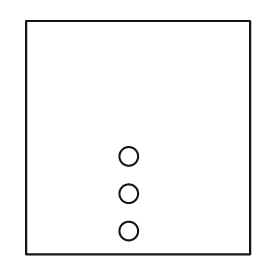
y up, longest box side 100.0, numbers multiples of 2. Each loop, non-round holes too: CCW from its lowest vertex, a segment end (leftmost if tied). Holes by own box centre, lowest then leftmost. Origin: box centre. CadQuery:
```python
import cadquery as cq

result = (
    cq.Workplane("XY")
    .moveTo(-48.0, -50.0)
    .lineTo(48.0, -50.0)
    .lineTo(48.0, 50.0)
    .lineTo(-48.0, 50.0)
    .close()
    .moveTo(-4.0, -40.0)
    .circle(4.0)
    .moveTo(-4.0, -24.0)
    .circle(4.0)
    .moveTo(-4.0, -8.0)
    .circle(4.0)
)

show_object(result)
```